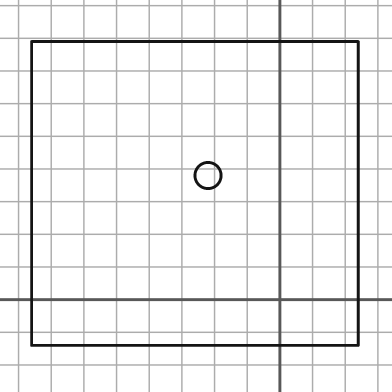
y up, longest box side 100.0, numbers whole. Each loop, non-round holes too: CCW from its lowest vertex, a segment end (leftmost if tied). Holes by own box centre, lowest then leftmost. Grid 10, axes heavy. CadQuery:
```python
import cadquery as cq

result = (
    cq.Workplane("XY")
    .moveTo(-76.0, -14.0)
    .lineTo(24.0, -14.0)
    .lineTo(24.0, 79.0)
    .lineTo(-76.0, 79.0)
    .close()
    .moveTo(-22.0, 38.0)
    .circle(4.0)
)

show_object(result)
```